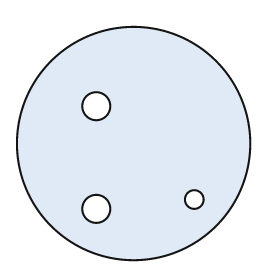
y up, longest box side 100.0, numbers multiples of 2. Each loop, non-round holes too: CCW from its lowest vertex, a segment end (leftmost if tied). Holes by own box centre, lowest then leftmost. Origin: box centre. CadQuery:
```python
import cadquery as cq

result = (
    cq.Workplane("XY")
    .moveTo(0.0, 0.0)
    .circle(50.0)
    .moveTo(-16.0, -28.0)
    .circle(6.0)
    .moveTo(26.0, -24.0)
    .circle(4.0)
    .moveTo(-16.0, 16.0)
    .circle(6.0)
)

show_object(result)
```